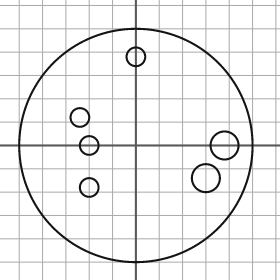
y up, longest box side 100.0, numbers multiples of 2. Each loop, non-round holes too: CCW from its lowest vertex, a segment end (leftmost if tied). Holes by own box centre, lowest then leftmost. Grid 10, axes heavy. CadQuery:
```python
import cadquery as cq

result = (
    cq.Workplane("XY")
    .moveTo(0.0, 0.0)
    .circle(50.0)
    .moveTo(-20.0, -18.0)
    .circle(4.0)
    .moveTo(30.0, -14.0)
    .circle(6.0)
    .moveTo(-20.0, 0.0)
    .circle(4.0)
    .moveTo(38.0, 0.0)
    .circle(6.0)
    .moveTo(-24.0, 12.0)
    .circle(4.0)
    .moveTo(0.0, 38.0)
    .circle(4.0)
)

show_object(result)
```